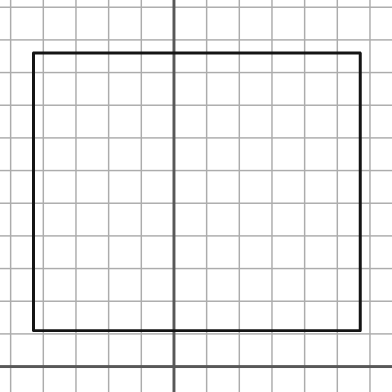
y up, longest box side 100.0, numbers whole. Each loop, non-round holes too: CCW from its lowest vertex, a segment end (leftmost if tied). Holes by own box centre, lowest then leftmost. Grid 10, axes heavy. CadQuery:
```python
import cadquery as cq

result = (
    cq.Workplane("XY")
    .moveTo(-43.0, 11.0)
    .lineTo(57.0, 11.0)
    .lineTo(57.0, 96.0)
    .lineTo(-43.0, 96.0)
    .close()
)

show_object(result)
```